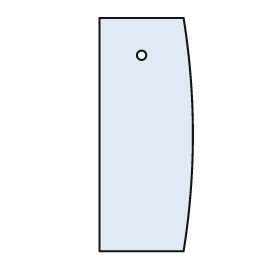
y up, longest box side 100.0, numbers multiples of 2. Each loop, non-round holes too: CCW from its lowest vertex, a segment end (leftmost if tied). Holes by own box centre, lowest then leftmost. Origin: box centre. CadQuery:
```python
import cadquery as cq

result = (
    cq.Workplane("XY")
    .moveTo(-20.0, -50.0)
    .lineTo(16.0, -50.0)
    .threePointArc((20.0, 0.0), (16.0, 50.0))
    .lineTo(-20.0, 50.0)
    .close()
    .moveTo(-2.0, 34.0)
    .circle(2.0)
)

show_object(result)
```